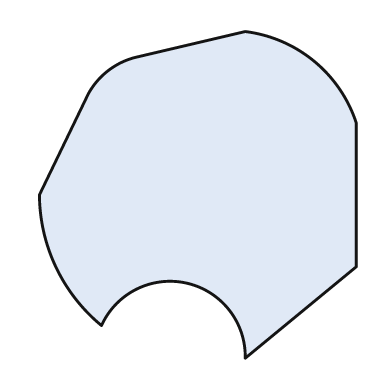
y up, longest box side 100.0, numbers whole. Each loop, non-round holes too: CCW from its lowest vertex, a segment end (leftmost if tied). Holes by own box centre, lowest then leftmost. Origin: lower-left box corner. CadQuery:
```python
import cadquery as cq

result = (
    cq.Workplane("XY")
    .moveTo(63.0, 0.0)
    .lineTo(97.0, 28.0)
    .lineTo(97.0, 72.0)
    .threePointArc((84.0, 91.0), (63.0, 100.0))
    .lineTo(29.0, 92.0)
    .threePointArc((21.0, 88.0), (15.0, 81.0))
    .lineTo(0.0, 50.0)
    .threePointArc((5.0, 28.0), (19.0, 10.0))
    .threePointArc((45.0, 23.0), (63.0, 0.0))
    .close()
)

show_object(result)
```